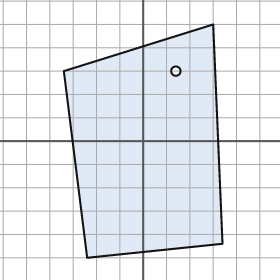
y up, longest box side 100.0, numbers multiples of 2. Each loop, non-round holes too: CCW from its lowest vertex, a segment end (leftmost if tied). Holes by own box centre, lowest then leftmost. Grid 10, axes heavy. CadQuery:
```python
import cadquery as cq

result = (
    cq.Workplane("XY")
    .moveTo(-24.0, -50.0)
    .lineTo(34.0, -44.0)
    .lineTo(30.0, 50.0)
    .lineTo(-34.0, 30.0)
    .close()
    .moveTo(14.0, 30.0)
    .circle(2.0)
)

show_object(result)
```